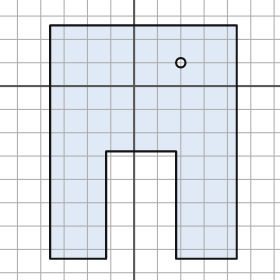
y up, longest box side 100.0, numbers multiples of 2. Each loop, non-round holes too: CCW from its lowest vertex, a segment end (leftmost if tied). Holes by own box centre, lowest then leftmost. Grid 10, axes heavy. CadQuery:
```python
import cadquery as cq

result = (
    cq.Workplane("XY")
    .moveTo(-36.0, -74.0)
    .lineTo(-12.0, -74.0)
    .lineTo(-12.0, -28.0)
    .lineTo(18.0, -28.0)
    .lineTo(18.0, -74.0)
    .lineTo(44.0, -74.0)
    .lineTo(44.0, 26.0)
    .lineTo(-36.0, 26.0)
    .close()
    .moveTo(20.0, 10.0)
    .circle(2.0)
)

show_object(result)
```